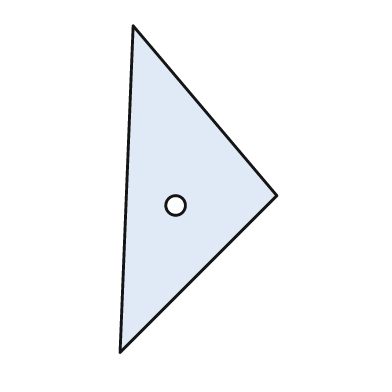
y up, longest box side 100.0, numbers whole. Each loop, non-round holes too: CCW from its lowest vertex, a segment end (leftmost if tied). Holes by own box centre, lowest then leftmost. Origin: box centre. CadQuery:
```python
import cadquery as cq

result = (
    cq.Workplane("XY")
    .moveTo(-24.0, -50.0)
    .lineTo(24.0, -2.0)
    .lineTo(-20.0, 50.0)
    .close()
    .moveTo(-7.0, -5.0)
    .circle(3.0)
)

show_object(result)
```